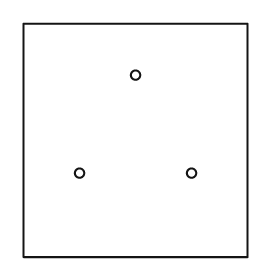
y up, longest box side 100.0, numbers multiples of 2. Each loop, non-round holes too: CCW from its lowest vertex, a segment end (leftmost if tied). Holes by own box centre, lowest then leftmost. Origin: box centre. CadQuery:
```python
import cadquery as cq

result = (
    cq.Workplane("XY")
    .moveTo(-48.0, -50.0)
    .lineTo(48.0, -50.0)
    .lineTo(48.0, 50.0)
    .lineTo(-48.0, 50.0)
    .close()
    .moveTo(-24.0, -14.0)
    .circle(2.0)
    .moveTo(24.0, -14.0)
    .circle(2.0)
    .moveTo(0.0, 28.0)
    .circle(2.0)
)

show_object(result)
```